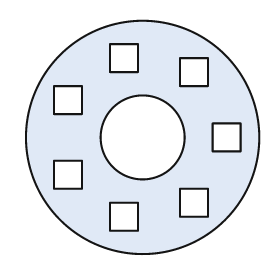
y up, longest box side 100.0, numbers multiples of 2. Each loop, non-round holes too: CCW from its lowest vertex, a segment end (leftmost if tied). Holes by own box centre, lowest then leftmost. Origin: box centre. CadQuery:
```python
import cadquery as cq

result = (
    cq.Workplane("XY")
    .moveTo(0.0, 0.0)
    .circle(50.0)
    .moveTo(-14.0, -40.0)
    .lineTo(-2.0, -40.0)
    .lineTo(-2.0, -28.0)
    .lineTo(-14.0, -28.0)
    .close()
    .moveTo(16.0, -34.0)
    .lineTo(28.0, -34.0)
    .lineTo(28.0, -22.0)
    .lineTo(16.0, -22.0)
    .close()
    .moveTo(-38.0, -22.0)
    .lineTo(-26.0, -22.0)
    .lineTo(-26.0, -10.0)
    .lineTo(-38.0, -10.0)
    .close()
    .moveTo(0.0, 0.0)
    .circle(18.0)
    .moveTo(30.0, -6.0)
    .lineTo(42.0, -6.0)
    .lineTo(42.0, 6.0)
    .lineTo(30.0, 6.0)
    .close()
    .moveTo(-38.0, 10.0)
    .lineTo(-26.0, 10.0)
    .lineTo(-26.0, 22.0)
    .lineTo(-38.0, 22.0)
    .close()
    .moveTo(16.0, 22.0)
    .lineTo(28.0, 22.0)
    .lineTo(28.0, 34.0)
    .lineTo(16.0, 34.0)
    .close()
    .moveTo(-14.0, 28.0)
    .lineTo(-2.0, 28.0)
    .lineTo(-2.0, 40.0)
    .lineTo(-14.0, 40.0)
    .close()
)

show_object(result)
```